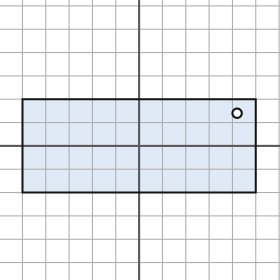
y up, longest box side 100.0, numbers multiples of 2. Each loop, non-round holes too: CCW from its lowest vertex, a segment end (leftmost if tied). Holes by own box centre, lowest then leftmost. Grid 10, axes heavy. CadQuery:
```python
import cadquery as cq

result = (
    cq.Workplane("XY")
    .moveTo(-50.0, -20.0)
    .lineTo(50.0, -20.0)
    .lineTo(50.0, 20.0)
    .lineTo(-50.0, 20.0)
    .close()
    .moveTo(42.0, 14.0)
    .circle(2.0)
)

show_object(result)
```